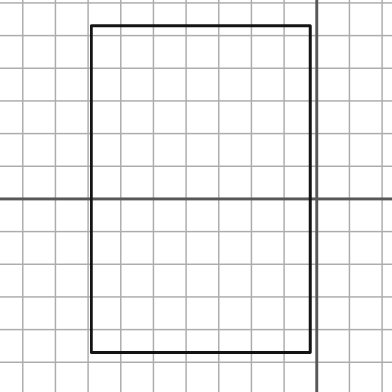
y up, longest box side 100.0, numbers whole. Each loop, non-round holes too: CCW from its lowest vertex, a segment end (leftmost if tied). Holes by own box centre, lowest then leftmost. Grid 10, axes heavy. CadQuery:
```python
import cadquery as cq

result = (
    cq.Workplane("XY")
    .moveTo(-69.0, -47.0)
    .lineTo(-2.0, -47.0)
    .lineTo(-2.0, 53.0)
    .lineTo(-69.0, 53.0)
    .close()
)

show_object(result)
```